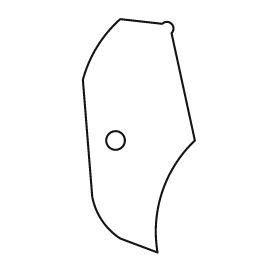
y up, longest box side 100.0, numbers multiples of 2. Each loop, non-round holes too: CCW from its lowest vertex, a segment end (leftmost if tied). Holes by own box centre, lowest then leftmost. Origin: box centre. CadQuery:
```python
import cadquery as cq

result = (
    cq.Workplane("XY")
    .moveTo(8.0, -50.0)
    .threePointArc((10.0, -24.0), (24.0, -2.0))
    .lineTo(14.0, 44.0)
    .threePointArc((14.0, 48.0), (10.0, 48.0))
    .lineTo(-8.0, 50.0)
    .threePointArc((-18.0, 38.0), (-24.0, 24.0))
    .lineTo(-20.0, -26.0)
    .threePointArc((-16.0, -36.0), (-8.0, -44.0))
    .close()
    .moveTo(-10.0, -2.0)
    .circle(4.0)
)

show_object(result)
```